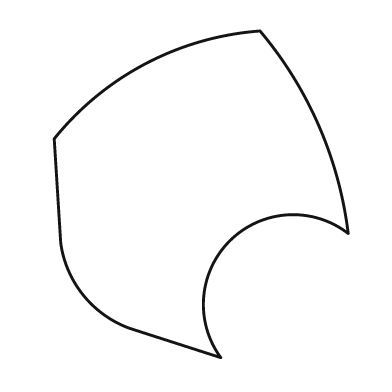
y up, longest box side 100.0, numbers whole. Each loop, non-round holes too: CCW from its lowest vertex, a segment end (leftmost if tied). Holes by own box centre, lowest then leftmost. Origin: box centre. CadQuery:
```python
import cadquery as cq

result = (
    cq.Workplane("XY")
    .moveTo(6.0, -50.0)
    .threePointArc((9.0, -14.0), (45.0, -12.0))
    .threePointArc((36.0, 21.0), (18.0, 50.0))
    .threePointArc((-17.0, 40.0), (-45.0, 17.0))
    .lineTo(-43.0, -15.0)
    .threePointArc((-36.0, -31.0), (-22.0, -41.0))
    .close()
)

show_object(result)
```